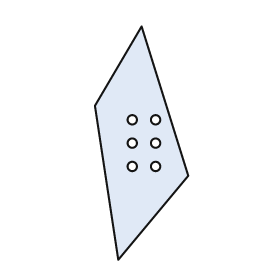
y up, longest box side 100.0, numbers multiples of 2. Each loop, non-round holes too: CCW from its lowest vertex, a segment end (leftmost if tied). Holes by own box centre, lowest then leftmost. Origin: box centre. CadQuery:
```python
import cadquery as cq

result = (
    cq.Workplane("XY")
    .moveTo(-10.0, -50.0)
    .lineTo(20.0, -14.0)
    .lineTo(0.0, 50.0)
    .lineTo(-20.0, 16.0)
    .close()
    .moveTo(-4.0, -10.0)
    .circle(2.0)
    .moveTo(6.0, -10.0)
    .circle(2.0)
    .moveTo(-4.0, 0.0)
    .circle(2.0)
    .moveTo(6.0, 0.0)
    .circle(2.0)
    .moveTo(-4.0, 10.0)
    .circle(2.0)
    .moveTo(6.0, 10.0)
    .circle(2.0)
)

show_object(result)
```